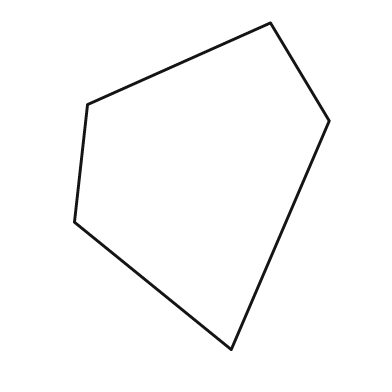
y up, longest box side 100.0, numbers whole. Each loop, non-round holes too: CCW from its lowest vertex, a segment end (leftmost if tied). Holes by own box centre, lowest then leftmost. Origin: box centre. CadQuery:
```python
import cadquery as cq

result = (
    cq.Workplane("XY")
    .moveTo(9.0, -50.0)
    .lineTo(39.0, 20.0)
    .lineTo(21.0, 50.0)
    .lineTo(-35.0, 25.0)
    .lineTo(-39.0, -11.0)
    .close()
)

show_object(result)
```